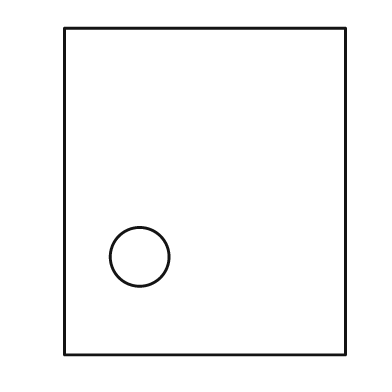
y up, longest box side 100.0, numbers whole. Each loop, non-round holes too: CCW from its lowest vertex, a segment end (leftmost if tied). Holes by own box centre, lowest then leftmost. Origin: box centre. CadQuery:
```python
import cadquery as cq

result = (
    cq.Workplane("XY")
    .moveTo(-43.0, -50.0)
    .lineTo(43.0, -50.0)
    .lineTo(43.0, 50.0)
    .lineTo(-43.0, 50.0)
    .close()
    .moveTo(-20.0, -20.0)
    .circle(9.0)
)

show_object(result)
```